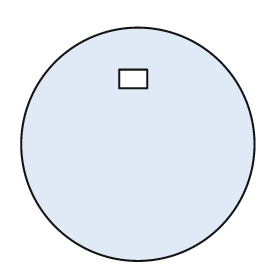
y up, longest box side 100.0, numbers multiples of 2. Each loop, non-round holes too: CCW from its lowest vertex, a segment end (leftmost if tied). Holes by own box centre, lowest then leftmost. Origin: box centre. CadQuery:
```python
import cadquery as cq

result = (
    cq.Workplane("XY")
    .moveTo(0.0, 0.0)
    .circle(50.0)
    .moveTo(-8.0, 24.0)
    .lineTo(4.0, 24.0)
    .lineTo(4.0, 32.0)
    .lineTo(-8.0, 32.0)
    .close()
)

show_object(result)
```